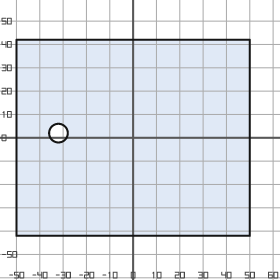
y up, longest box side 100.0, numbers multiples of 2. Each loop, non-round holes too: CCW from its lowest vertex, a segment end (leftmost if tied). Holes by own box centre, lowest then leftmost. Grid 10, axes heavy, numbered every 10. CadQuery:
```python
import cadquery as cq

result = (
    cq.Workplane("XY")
    .moveTo(-50.0, -42.0)
    .lineTo(50.0, -42.0)
    .lineTo(50.0, 42.0)
    .lineTo(-50.0, 42.0)
    .close()
    .moveTo(-32.0, 2.0)
    .circle(4.0)
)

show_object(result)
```